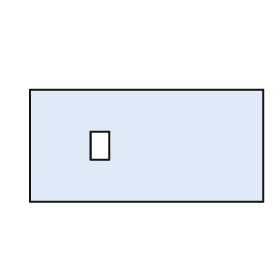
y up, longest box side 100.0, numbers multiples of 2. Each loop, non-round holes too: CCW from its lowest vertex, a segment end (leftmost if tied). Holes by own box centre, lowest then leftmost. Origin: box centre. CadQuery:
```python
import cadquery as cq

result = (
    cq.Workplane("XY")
    .moveTo(-50.0, -24.0)
    .lineTo(50.0, -24.0)
    .lineTo(50.0, 24.0)
    .lineTo(-50.0, 24.0)
    .close()
    .moveTo(-24.0, -6.0)
    .lineTo(-16.0, -6.0)
    .lineTo(-16.0, 6.0)
    .lineTo(-24.0, 6.0)
    .close()
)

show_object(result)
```